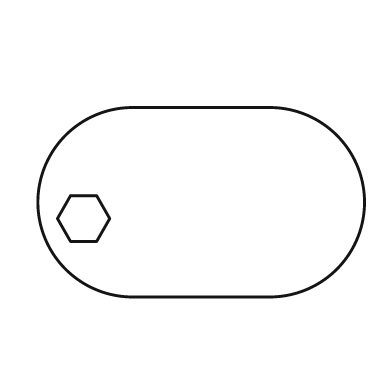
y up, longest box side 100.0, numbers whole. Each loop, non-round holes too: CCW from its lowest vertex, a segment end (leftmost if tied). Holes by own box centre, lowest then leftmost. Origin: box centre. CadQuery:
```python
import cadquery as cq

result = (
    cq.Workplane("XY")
    .moveTo(-21.0, -29.0)
    .lineTo(21.0, -29.0)
    .threePointArc((50.0, 0.0), (21.0, 29.0))
    .lineTo(-21.0, 29.0)
    .threePointArc((-50.0, 0.0), (-21.0, -29.0))
    .close()
    .moveTo(-40.0, -12.0)
    .lineTo(-32.0, -12.0)
    .lineTo(-28.0, -5.0)
    .lineTo(-32.0, 2.0)
    .lineTo(-40.0, 2.0)
    .lineTo(-44.0, -5.0)
    .close()
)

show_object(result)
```